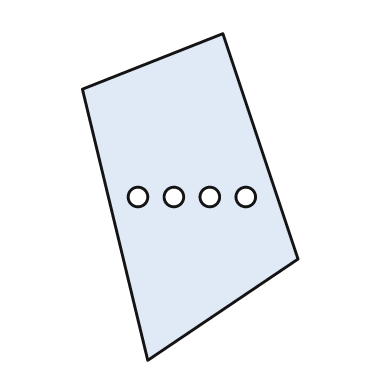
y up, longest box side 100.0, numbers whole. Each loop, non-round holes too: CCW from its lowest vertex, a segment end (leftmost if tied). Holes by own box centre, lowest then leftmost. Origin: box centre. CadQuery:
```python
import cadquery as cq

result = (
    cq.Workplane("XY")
    .moveTo(-13.0, -50.0)
    .lineTo(33.0, -19.0)
    .lineTo(10.0, 50.0)
    .lineTo(-33.0, 33.0)
    .close()
    .moveTo(-16.0, 0.0)
    .circle(3.0)
    .moveTo(-5.0, 0.0)
    .circle(3.0)
    .moveTo(6.0, 0.0)
    .circle(3.0)
    .moveTo(17.0, 0.0)
    .circle(3.0)
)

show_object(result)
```